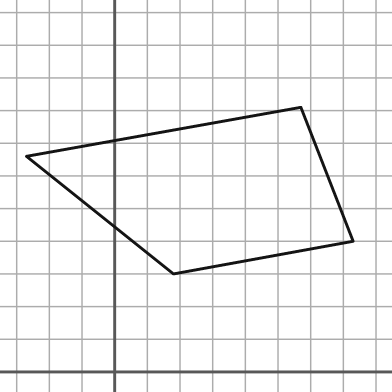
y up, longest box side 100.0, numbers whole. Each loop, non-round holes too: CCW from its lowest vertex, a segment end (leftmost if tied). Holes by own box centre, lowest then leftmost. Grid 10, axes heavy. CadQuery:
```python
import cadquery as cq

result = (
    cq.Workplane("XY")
    .moveTo(18.0, 30.0)
    .lineTo(73.0, 40.0)
    .lineTo(57.0, 81.0)
    .lineTo(-27.0, 66.0)
    .close()
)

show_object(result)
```